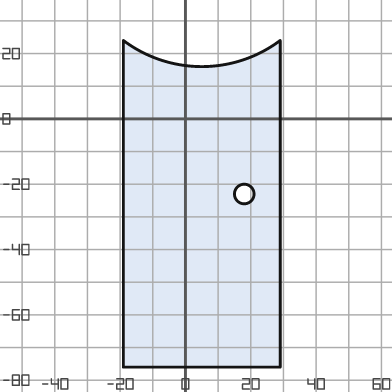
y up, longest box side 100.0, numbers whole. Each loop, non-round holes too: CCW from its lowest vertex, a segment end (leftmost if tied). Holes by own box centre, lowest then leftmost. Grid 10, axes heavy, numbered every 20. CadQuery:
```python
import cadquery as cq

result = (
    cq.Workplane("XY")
    .moveTo(-19.0, -76.0)
    .lineTo(29.0, -76.0)
    .lineTo(29.0, 24.0)
    .threePointArc((5.0, 16.0), (-19.0, 24.0))
    .close()
    .moveTo(18.0, -23.0)
    .circle(3.0)
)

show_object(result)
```